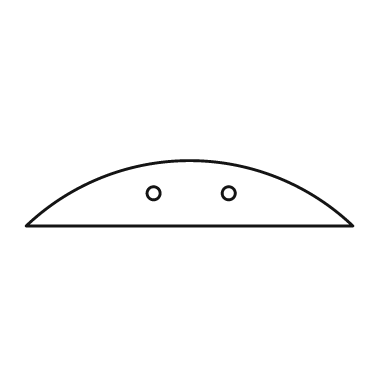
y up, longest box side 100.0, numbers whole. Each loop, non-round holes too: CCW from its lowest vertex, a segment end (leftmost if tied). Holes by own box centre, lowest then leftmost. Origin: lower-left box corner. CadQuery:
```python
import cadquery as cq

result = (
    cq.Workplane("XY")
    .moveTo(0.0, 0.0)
    .lineTo(100.0, 0.0)
    .threePointArc((50.0, 20.0), (0.0, 0.0))
    .close()
    .moveTo(39.0, 10.0)
    .circle(2.0)
    .moveTo(62.0, 10.0)
    .circle(2.0)
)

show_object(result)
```